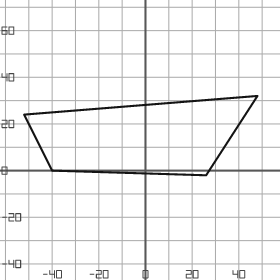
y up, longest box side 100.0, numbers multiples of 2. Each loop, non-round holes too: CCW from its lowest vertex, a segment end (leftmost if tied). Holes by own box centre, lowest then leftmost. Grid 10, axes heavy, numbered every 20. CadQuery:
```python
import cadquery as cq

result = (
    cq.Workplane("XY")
    .moveTo(26.0, -2.0)
    .lineTo(48.0, 32.0)
    .lineTo(-52.0, 24.0)
    .lineTo(-40.0, 0.0)
    .close()
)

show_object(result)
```